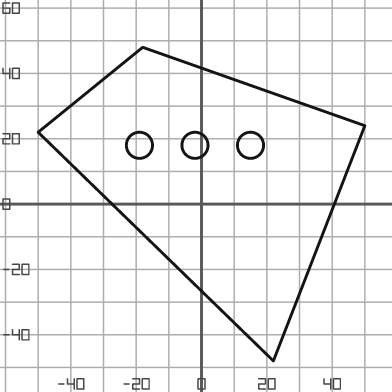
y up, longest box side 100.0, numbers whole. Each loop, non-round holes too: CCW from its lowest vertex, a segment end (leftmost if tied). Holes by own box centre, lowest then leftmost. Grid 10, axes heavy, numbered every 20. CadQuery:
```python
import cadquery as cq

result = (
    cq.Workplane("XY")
    .moveTo(22.0, -48.0)
    .lineTo(50.0, 24.0)
    .lineTo(-18.0, 48.0)
    .lineTo(-50.0, 22.0)
    .close()
    .moveTo(-19.0, 18.0)
    .circle(4.0)
    .moveTo(-2.0, 18.0)
    .circle(4.0)
    .moveTo(15.0, 18.0)
    .circle(4.0)
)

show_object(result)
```